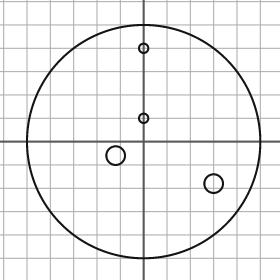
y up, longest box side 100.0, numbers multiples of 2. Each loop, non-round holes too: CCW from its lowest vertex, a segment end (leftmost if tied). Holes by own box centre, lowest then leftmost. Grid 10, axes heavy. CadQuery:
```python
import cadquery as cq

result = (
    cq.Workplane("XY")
    .moveTo(0.0, 0.0)
    .circle(50.0)
    .moveTo(30.0, -18.0)
    .circle(4.0)
    .moveTo(-12.0, -6.0)
    .circle(4.0)
    .moveTo(0.0, 10.0)
    .circle(2.0)
    .moveTo(0.0, 40.0)
    .circle(2.0)
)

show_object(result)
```